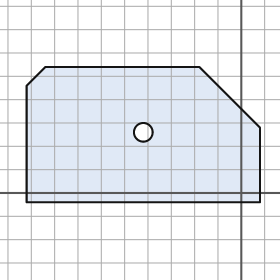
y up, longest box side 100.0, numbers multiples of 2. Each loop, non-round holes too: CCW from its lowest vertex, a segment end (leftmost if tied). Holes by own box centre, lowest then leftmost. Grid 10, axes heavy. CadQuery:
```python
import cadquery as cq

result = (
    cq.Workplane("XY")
    .moveTo(-92.0, -4.0)
    .lineTo(8.0, -4.0)
    .lineTo(8.0, 28.0)
    .lineTo(-18.0, 54.0)
    .lineTo(-84.0, 54.0)
    .lineTo(-92.0, 46.0)
    .close()
    .moveTo(-42.0, 26.0)
    .circle(4.0)
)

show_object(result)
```